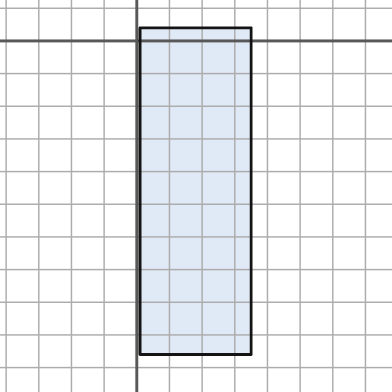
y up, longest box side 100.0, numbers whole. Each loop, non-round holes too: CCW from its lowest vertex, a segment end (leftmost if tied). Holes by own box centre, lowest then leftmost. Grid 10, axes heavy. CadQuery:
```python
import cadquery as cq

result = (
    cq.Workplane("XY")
    .moveTo(1.0, -96.0)
    .lineTo(35.0, -96.0)
    .lineTo(35.0, 4.0)
    .lineTo(1.0, 4.0)
    .close()
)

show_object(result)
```